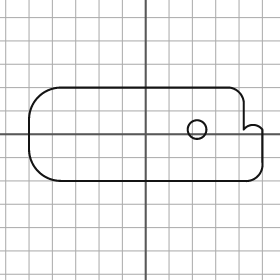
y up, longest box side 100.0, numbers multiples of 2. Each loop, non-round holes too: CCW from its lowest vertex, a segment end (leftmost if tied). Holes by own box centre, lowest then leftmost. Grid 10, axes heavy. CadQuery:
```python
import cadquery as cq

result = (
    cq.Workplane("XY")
    .moveTo(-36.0, -20.0)
    .lineTo(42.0, -20.0)
    .threePointArc((48.0, -18.0), (50.0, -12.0))
    .lineTo(50.0, 2.0)
    .threePointArc((46.0, 4.0), (42.0, 2.0))
    .lineTo(42.0, 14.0)
    .threePointArc((40.0, 18.0), (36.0, 20.0))
    .lineTo(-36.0, 20.0)
    .threePointArc((-46.0, 16.0), (-50.0, 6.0))
    .lineTo(-50.0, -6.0)
    .threePointArc((-46.0, -16.0), (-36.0, -20.0))
    .close()
    .moveTo(22.0, 2.0)
    .circle(4.0)
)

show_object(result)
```